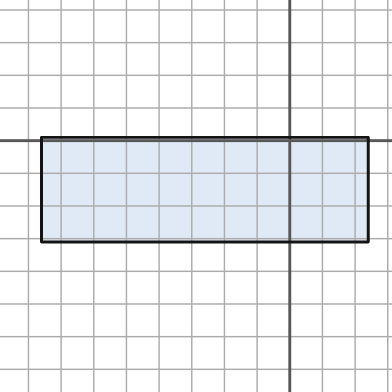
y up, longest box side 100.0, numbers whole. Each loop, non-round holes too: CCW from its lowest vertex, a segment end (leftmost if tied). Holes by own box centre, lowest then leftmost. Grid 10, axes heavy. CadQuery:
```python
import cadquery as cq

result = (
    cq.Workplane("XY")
    .moveTo(-76.0, -31.0)
    .lineTo(24.0, -31.0)
    .lineTo(24.0, 1.0)
    .lineTo(-76.0, 1.0)
    .close()
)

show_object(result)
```